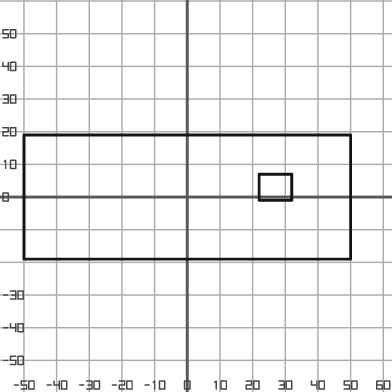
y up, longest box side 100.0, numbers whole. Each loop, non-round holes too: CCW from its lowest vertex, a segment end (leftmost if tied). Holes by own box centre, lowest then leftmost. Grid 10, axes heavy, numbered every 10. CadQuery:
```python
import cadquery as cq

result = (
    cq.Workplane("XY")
    .moveTo(-50.0, -19.0)
    .lineTo(50.0, -19.0)
    .lineTo(50.0, 19.0)
    .lineTo(-50.0, 19.0)
    .close()
    .moveTo(22.0, -1.0)
    .lineTo(32.0, -1.0)
    .lineTo(32.0, 7.0)
    .lineTo(22.0, 7.0)
    .close()
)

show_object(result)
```